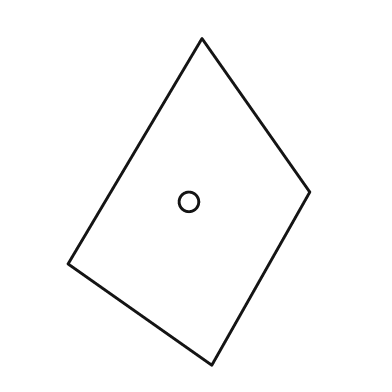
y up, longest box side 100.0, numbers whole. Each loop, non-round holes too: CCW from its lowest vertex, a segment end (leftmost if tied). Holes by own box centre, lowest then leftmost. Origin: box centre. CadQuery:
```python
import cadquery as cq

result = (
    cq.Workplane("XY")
    .moveTo(7.0, -50.0)
    .lineTo(37.0, 3.0)
    .lineTo(4.0, 50.0)
    .lineTo(-37.0, -19.0)
    .close()
    .moveTo(0.0, 0.0)
    .circle(3.0)
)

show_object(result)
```